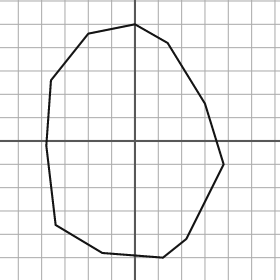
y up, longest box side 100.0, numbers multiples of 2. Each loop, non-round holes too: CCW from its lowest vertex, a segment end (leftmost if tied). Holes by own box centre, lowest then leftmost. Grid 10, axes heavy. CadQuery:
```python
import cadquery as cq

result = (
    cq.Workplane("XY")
    .moveTo(12.0, -50.0)
    .lineTo(22.0, -42.0)
    .lineTo(38.0, -10.0)
    .lineTo(30.0, 16.0)
    .lineTo(14.0, 42.0)
    .lineTo(0.0, 50.0)
    .lineTo(-20.0, 46.0)
    .lineTo(-36.0, 26.0)
    .lineTo(-38.0, -2.0)
    .lineTo(-34.0, -36.0)
    .lineTo(-14.0, -48.0)
    .close()
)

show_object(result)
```